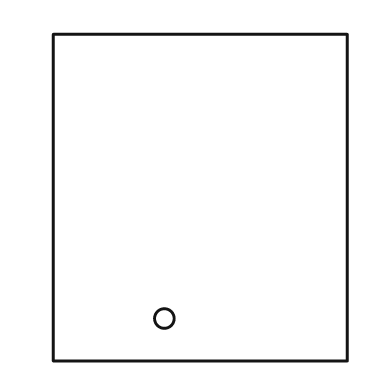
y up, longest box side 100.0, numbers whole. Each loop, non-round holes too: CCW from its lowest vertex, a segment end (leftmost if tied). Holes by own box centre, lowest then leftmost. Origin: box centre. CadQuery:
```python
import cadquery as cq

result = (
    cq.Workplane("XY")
    .moveTo(-45.0, -50.0)
    .lineTo(45.0, -50.0)
    .lineTo(45.0, 50.0)
    .lineTo(-45.0, 50.0)
    .close()
    .moveTo(-11.0, -37.0)
    .circle(3.0)
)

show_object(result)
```